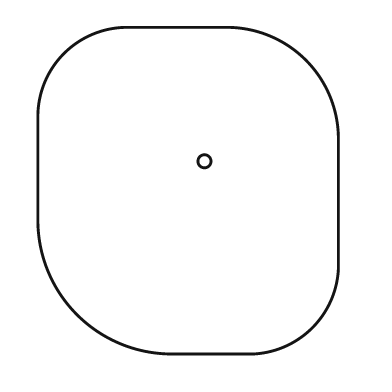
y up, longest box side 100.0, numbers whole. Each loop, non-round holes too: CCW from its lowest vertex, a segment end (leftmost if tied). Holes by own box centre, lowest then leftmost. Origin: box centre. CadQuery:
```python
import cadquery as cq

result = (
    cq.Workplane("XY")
    .moveTo(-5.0, -50.0)
    .lineTo(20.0, -50.0)
    .threePointArc((38.0, -42.0), (46.0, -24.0))
    .lineTo(46.0, 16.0)
    .threePointArc((36.0, 40.0), (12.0, 50.0))
    .lineTo(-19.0, 50.0)
    .threePointArc((-38.0, 42.0), (-46.0, 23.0))
    .lineTo(-46.0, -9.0)
    .threePointArc((-34.0, -38.0), (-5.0, -50.0))
    .close()
    .moveTo(5.0, 9.0)
    .circle(2.0)
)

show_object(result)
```